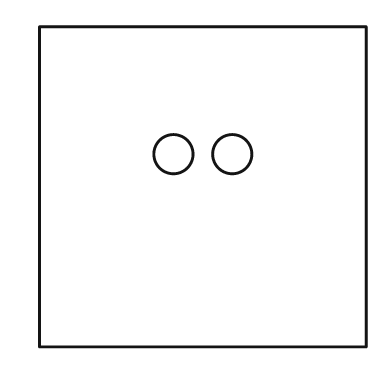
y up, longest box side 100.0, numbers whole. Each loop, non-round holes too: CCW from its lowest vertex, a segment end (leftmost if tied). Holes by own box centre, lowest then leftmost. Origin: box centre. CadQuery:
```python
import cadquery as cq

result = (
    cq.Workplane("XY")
    .moveTo(-50.0, -49.0)
    .lineTo(50.0, -49.0)
    .lineTo(50.0, 49.0)
    .lineTo(-50.0, 49.0)
    .close()
    .moveTo(-9.0, 10.0)
    .circle(6.0)
    .moveTo(9.0, 10.0)
    .circle(6.0)
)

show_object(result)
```